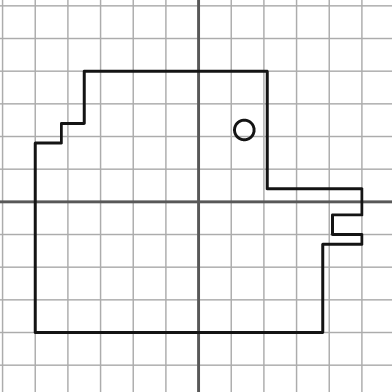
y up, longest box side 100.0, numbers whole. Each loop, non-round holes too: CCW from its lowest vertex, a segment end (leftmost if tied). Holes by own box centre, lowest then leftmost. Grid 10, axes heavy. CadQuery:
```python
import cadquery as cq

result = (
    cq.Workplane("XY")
    .moveTo(-50.0, -40.0)
    .lineTo(38.0, -40.0)
    .lineTo(38.0, -13.0)
    .lineTo(50.0, -13.0)
    .lineTo(50.0, -10.0)
    .lineTo(41.0, -10.0)
    .lineTo(41.0, -4.0)
    .lineTo(50.0, -4.0)
    .lineTo(50.0, 4.0)
    .lineTo(21.0, 4.0)
    .lineTo(21.0, 40.0)
    .lineTo(-35.0, 40.0)
    .lineTo(-35.0, 24.0)
    .lineTo(-42.0, 24.0)
    .lineTo(-42.0, 18.0)
    .lineTo(-50.0, 18.0)
    .close()
    .moveTo(14.0, 22.0)
    .circle(3.0)
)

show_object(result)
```